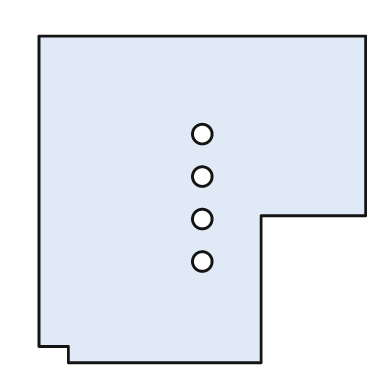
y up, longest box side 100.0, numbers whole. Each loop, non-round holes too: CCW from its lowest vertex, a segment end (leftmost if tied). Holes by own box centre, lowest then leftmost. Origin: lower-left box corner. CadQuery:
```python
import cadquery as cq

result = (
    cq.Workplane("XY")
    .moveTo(9.0, 0.0)
    .lineTo(68.0, 0.0)
    .lineTo(68.0, 45.0)
    .lineTo(100.0, 45.0)
    .lineTo(100.0, 100.0)
    .lineTo(0.0, 100.0)
    .lineTo(0.0, 5.0)
    .lineTo(9.0, 5.0)
    .close()
    .moveTo(50.0, 31.0)
    .circle(3.0)
    .moveTo(50.0, 44.0)
    .circle(3.0)
    .moveTo(50.0, 57.0)
    .circle(3.0)
    .moveTo(50.0, 70.0)
    .circle(3.0)
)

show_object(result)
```